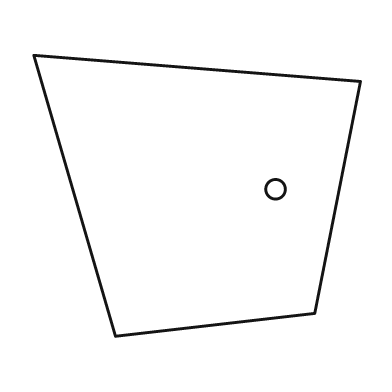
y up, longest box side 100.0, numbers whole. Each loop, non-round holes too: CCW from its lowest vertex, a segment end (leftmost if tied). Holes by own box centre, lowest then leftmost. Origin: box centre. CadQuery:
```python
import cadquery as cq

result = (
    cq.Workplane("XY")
    .moveTo(-25.0, -43.0)
    .lineTo(36.0, -36.0)
    .lineTo(50.0, 35.0)
    .lineTo(-50.0, 43.0)
    .close()
    .moveTo(24.0, 2.0)
    .circle(3.0)
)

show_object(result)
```